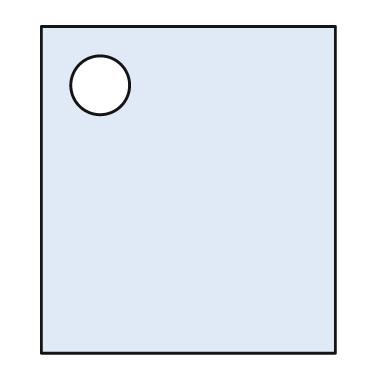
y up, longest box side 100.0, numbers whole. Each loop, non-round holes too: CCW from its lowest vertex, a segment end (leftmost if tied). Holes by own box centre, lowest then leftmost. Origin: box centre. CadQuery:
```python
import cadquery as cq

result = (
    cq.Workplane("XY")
    .moveTo(-45.0, -50.0)
    .lineTo(45.0, -50.0)
    .lineTo(45.0, 50.0)
    .lineTo(-45.0, 50.0)
    .close()
    .moveTo(-27.0, 32.0)
    .circle(9.0)
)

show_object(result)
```